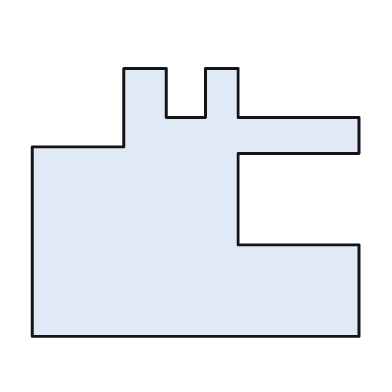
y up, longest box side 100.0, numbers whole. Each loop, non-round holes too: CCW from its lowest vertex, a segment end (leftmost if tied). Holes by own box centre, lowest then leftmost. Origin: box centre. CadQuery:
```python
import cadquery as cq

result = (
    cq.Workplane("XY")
    .moveTo(-50.0, -41.0)
    .lineTo(50.0, -41.0)
    .lineTo(50.0, -13.0)
    .lineTo(13.0, -13.0)
    .lineTo(13.0, 15.0)
    .lineTo(50.0, 15.0)
    .lineTo(50.0, 26.0)
    .lineTo(13.0, 26.0)
    .lineTo(13.0, 41.0)
    .lineTo(3.0, 41.0)
    .lineTo(3.0, 26.0)
    .lineTo(-9.0, 26.0)
    .lineTo(-9.0, 41.0)
    .lineTo(-22.0, 41.0)
    .lineTo(-22.0, 17.0)
    .lineTo(-50.0, 17.0)
    .close()
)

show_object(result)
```